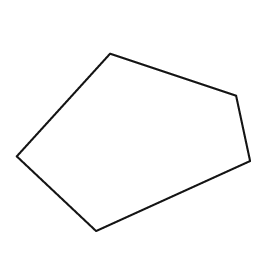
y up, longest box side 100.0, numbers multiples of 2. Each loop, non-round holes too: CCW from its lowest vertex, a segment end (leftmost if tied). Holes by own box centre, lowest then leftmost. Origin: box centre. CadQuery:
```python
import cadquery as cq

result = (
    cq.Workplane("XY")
    .moveTo(-16.0, -38.0)
    .lineTo(50.0, -8.0)
    .lineTo(44.0, 20.0)
    .lineTo(-10.0, 38.0)
    .lineTo(-50.0, -6.0)
    .close()
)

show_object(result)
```